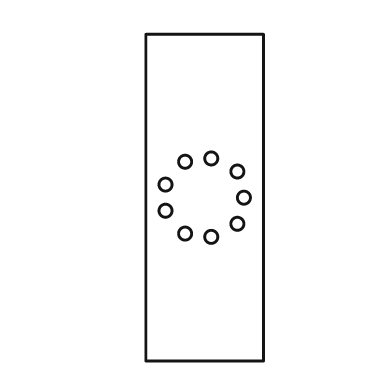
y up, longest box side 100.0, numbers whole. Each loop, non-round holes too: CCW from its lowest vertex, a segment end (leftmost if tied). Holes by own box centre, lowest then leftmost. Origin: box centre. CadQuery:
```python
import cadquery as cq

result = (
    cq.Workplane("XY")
    .moveTo(-18.0, -50.0)
    .lineTo(18.0, -50.0)
    .lineTo(18.0, 50.0)
    .lineTo(-18.0, 50.0)
    .close()
    .moveTo(2.0, -12.0)
    .circle(2.0)
    .moveTo(-6.0, -11.0)
    .circle(2.0)
    .moveTo(10.0, -8.0)
    .circle(2.0)
    .moveTo(-12.0, -4.0)
    .circle(2.0)
    .moveTo(12.0, 0.0)
    .circle(2.0)
    .moveTo(-12.0, 4.0)
    .circle(2.0)
    .moveTo(10.0, 8.0)
    .circle(2.0)
    .moveTo(-6.0, 11.0)
    .circle(2.0)
    .moveTo(2.0, 12.0)
    .circle(2.0)
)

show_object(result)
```